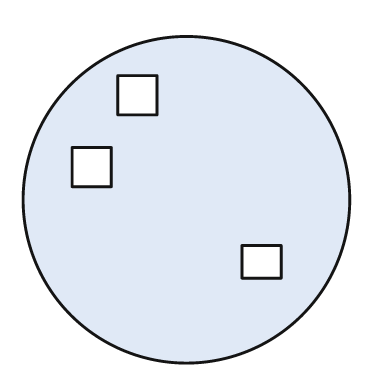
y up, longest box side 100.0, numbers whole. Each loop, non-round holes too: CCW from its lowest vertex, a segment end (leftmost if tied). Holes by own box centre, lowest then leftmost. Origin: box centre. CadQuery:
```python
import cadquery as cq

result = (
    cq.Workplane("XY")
    .moveTo(0.0, 0.0)
    .circle(50.0)
    .moveTo(17.0, -24.0)
    .lineTo(29.0, -24.0)
    .lineTo(29.0, -14.0)
    .lineTo(17.0, -14.0)
    .close()
    .moveTo(-35.0, 4.0)
    .lineTo(-23.0, 4.0)
    .lineTo(-23.0, 16.0)
    .lineTo(-35.0, 16.0)
    .close()
    .moveTo(-21.0, 26.0)
    .lineTo(-9.0, 26.0)
    .lineTo(-9.0, 38.0)
    .lineTo(-21.0, 38.0)
    .close()
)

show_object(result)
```